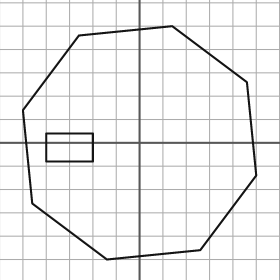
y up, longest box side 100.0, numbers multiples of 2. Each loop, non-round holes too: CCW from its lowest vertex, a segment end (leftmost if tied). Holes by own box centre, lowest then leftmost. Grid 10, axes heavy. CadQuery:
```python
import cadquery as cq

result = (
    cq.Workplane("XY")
    .moveTo(-14.0, -50.0)
    .lineTo(26.0, -46.0)
    .lineTo(50.0, -14.0)
    .lineTo(46.0, 26.0)
    .lineTo(14.0, 50.0)
    .lineTo(-26.0, 46.0)
    .lineTo(-50.0, 14.0)
    .lineTo(-46.0, -26.0)
    .close()
    .moveTo(-40.0, -8.0)
    .lineTo(-20.0, -8.0)
    .lineTo(-20.0, 4.0)
    .lineTo(-40.0, 4.0)
    .close()
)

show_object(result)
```